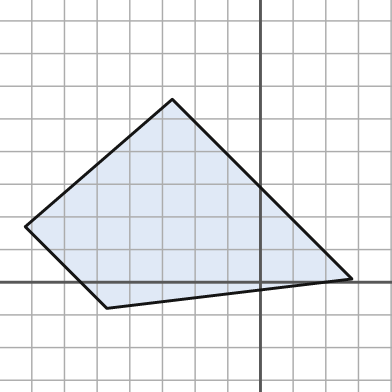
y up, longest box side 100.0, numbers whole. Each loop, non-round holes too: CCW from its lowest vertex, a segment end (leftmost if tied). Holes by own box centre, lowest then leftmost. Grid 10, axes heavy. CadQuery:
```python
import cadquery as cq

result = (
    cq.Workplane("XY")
    .moveTo(-47.0, -8.0)
    .lineTo(28.0, 1.0)
    .lineTo(-27.0, 56.0)
    .lineTo(-72.0, 17.0)
    .close()
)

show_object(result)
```